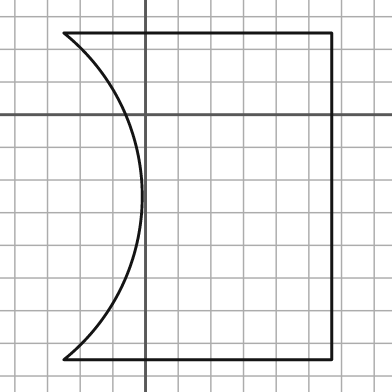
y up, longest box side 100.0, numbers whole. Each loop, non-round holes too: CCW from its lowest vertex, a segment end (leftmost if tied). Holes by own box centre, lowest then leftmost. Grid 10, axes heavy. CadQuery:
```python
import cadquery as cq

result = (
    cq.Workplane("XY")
    .moveTo(-25.0, -75.0)
    .lineTo(57.0, -75.0)
    .lineTo(57.0, 25.0)
    .lineTo(-25.0, 25.0)
    .threePointArc((-1.0, -25.0), (-25.0, -75.0))
    .close()
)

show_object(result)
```